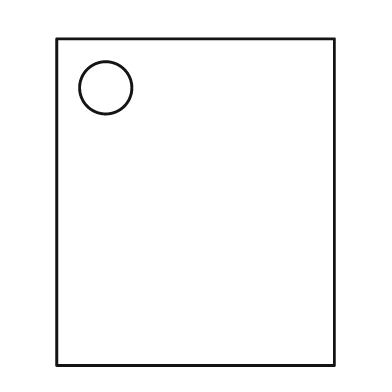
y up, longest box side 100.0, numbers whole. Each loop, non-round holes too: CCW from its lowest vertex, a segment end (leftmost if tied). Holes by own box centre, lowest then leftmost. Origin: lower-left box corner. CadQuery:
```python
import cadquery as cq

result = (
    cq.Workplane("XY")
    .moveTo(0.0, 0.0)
    .lineTo(85.0, 0.0)
    .lineTo(85.0, 100.0)
    .lineTo(0.0, 100.0)
    .close()
    .moveTo(15.0, 85.0)
    .circle(8.0)
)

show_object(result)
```